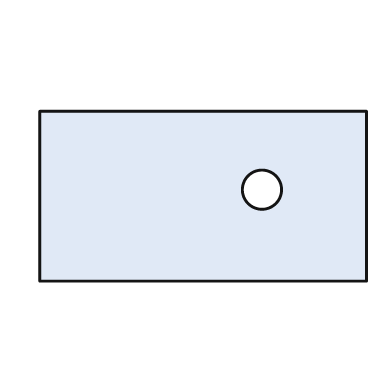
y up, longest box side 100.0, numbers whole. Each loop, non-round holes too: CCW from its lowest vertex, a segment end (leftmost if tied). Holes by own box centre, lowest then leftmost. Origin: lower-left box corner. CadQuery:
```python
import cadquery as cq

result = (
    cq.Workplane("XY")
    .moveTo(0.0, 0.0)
    .lineTo(100.0, 0.0)
    .lineTo(100.0, 52.0)
    .lineTo(0.0, 52.0)
    .close()
    .moveTo(68.0, 28.0)
    .circle(6.0)
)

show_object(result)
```